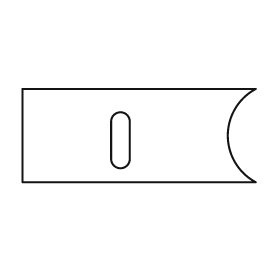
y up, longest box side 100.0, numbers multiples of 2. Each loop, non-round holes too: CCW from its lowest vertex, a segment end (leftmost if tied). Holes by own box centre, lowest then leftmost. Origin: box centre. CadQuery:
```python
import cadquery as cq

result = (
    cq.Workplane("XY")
    .moveTo(-50.0, -20.0)
    .lineTo(50.0, -20.0)
    .threePointArc((38.0, 0.0), (50.0, 20.0))
    .lineTo(-50.0, 20.0)
    .close()
    .moveTo(-12.0, -10.0)
    .threePointArc((-8.0, -14.0), (-4.0, -10.0))
    .lineTo(-4.0, 6.0)
    .threePointArc((-8.0, 10.0), (-12.0, 6.0))
    .close()
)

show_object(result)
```